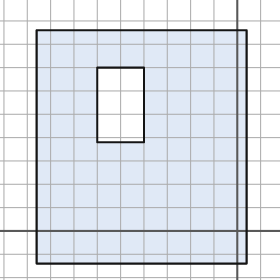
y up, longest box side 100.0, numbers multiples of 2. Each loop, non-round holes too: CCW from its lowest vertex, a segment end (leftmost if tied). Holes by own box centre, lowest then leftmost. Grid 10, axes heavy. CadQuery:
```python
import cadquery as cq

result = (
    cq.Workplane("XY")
    .moveTo(-86.0, -14.0)
    .lineTo(4.0, -14.0)
    .lineTo(4.0, 86.0)
    .lineTo(-86.0, 86.0)
    .close()
    .moveTo(-60.0, 38.0)
    .lineTo(-40.0, 38.0)
    .lineTo(-40.0, 70.0)
    .lineTo(-60.0, 70.0)
    .close()
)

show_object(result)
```